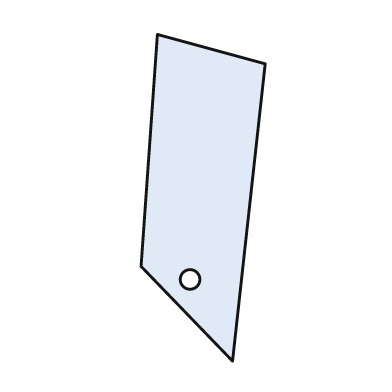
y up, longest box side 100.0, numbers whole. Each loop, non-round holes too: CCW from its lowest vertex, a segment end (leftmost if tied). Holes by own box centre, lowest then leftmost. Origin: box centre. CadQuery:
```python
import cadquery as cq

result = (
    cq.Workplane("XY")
    .moveTo(9.0, -50.0)
    .lineTo(19.0, 41.0)
    .lineTo(-14.0, 50.0)
    .lineTo(-19.0, -21.0)
    .close()
    .moveTo(-4.0, -25.0)
    .circle(3.0)
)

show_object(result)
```